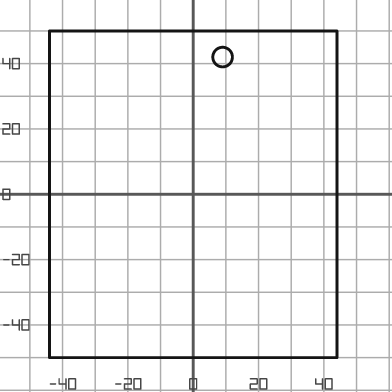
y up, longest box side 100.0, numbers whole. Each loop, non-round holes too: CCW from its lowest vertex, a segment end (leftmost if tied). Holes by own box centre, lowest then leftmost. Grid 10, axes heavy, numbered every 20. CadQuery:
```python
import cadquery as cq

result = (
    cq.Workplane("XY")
    .moveTo(-44.0, -50.0)
    .lineTo(44.0, -50.0)
    .lineTo(44.0, 50.0)
    .lineTo(-44.0, 50.0)
    .close()
    .moveTo(9.0, 42.0)
    .circle(3.0)
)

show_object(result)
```